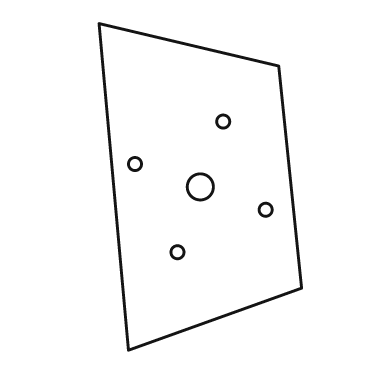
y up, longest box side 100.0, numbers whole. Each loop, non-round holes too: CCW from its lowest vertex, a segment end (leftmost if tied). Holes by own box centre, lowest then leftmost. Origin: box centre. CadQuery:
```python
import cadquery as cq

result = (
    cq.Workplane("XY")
    .moveTo(-22.0, -50.0)
    .lineTo(31.0, -31.0)
    .lineTo(24.0, 37.0)
    .lineTo(-31.0, 50.0)
    .close()
    .moveTo(-7.0, -20.0)
    .circle(2.0)
    .moveTo(20.0, -7.0)
    .circle(2.0)
    .moveTo(0.0, 0.0)
    .circle(4.0)
    .moveTo(-20.0, 7.0)
    .circle(2.0)
    .moveTo(7.0, 20.0)
    .circle(2.0)
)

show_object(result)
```